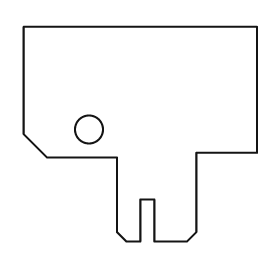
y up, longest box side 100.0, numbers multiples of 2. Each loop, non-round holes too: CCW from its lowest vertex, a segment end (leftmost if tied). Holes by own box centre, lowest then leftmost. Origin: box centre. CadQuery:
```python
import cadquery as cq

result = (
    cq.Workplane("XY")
    .moveTo(-6.0, -46.0)
    .lineTo(0.0, -46.0)
    .lineTo(0.0, -28.0)
    .lineTo(6.0, -28.0)
    .lineTo(6.0, -46.0)
    .lineTo(20.0, -46.0)
    .lineTo(24.0, -42.0)
    .lineTo(24.0, -8.0)
    .lineTo(50.0, -8.0)
    .lineTo(50.0, 46.0)
    .lineTo(-50.0, 46.0)
    .lineTo(-50.0, 0.0)
    .lineTo(-40.0, -10.0)
    .lineTo(-10.0, -10.0)
    .lineTo(-10.0, -42.0)
    .close()
    .moveTo(-22.0, 2.0)
    .circle(6.0)
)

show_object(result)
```